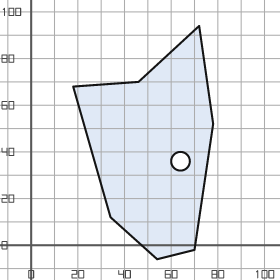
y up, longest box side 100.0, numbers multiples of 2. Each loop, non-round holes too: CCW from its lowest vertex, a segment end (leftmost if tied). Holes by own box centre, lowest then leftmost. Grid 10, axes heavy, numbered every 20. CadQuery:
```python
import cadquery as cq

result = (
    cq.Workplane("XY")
    .moveTo(54.0, -6.0)
    .lineTo(70.0, -2.0)
    .lineTo(78.0, 52.0)
    .lineTo(72.0, 94.0)
    .lineTo(46.0, 70.0)
    .lineTo(18.0, 68.0)
    .lineTo(34.0, 12.0)
    .close()
    .moveTo(64.0, 36.0)
    .circle(4.0)
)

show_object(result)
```